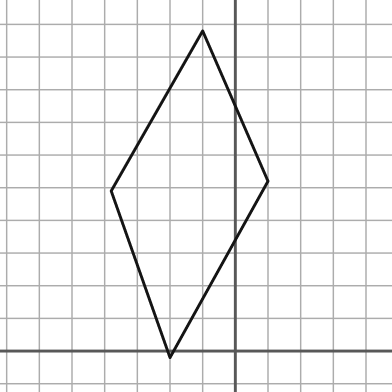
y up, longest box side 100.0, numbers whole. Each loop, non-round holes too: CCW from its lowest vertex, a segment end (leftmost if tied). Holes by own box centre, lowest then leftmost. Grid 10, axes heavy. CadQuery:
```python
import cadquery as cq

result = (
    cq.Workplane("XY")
    .moveTo(-20.0, -2.0)
    .lineTo(10.0, 52.0)
    .lineTo(-10.0, 98.0)
    .lineTo(-38.0, 49.0)
    .close()
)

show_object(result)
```